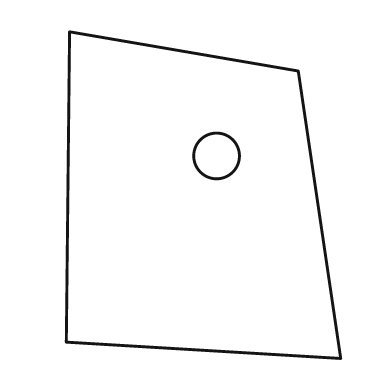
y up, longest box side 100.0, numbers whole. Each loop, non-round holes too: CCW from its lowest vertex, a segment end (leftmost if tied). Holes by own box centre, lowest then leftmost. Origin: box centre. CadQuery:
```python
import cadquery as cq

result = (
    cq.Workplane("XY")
    .moveTo(42.0, -50.0)
    .lineTo(29.0, 38.0)
    .lineTo(-41.0, 50.0)
    .lineTo(-42.0, -45.0)
    .close()
    .moveTo(4.0, 12.0)
    .circle(7.0)
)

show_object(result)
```